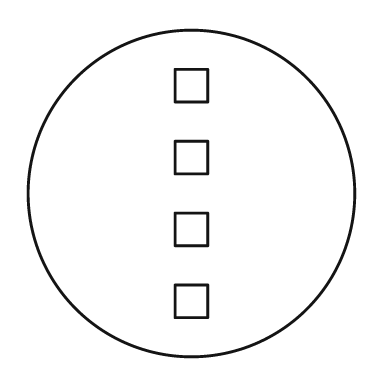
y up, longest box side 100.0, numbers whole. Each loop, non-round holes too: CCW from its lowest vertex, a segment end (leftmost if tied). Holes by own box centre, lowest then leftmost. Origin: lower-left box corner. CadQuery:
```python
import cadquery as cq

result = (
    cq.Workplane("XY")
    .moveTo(50.0, 50.0)
    .circle(50.0)
    .moveTo(45.0, 12.0)
    .lineTo(55.0, 12.0)
    .lineTo(55.0, 22.0)
    .lineTo(45.0, 22.0)
    .close()
    .moveTo(45.0, 34.0)
    .lineTo(55.0, 34.0)
    .lineTo(55.0, 44.0)
    .lineTo(45.0, 44.0)
    .close()
    .moveTo(45.0, 56.0)
    .lineTo(55.0, 56.0)
    .lineTo(55.0, 66.0)
    .lineTo(45.0, 66.0)
    .close()
    .moveTo(45.0, 78.0)
    .lineTo(55.0, 78.0)
    .lineTo(55.0, 88.0)
    .lineTo(45.0, 88.0)
    .close()
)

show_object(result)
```